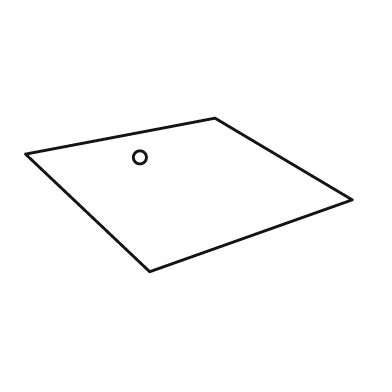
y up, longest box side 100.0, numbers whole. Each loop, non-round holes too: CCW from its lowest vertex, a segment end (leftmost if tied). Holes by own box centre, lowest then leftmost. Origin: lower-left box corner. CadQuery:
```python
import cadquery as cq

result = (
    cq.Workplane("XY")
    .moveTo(38.0, 0.0)
    .lineTo(100.0, 22.0)
    .lineTo(58.0, 47.0)
    .lineTo(0.0, 36.0)
    .close()
    .moveTo(35.0, 35.0)
    .circle(2.0)
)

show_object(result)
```